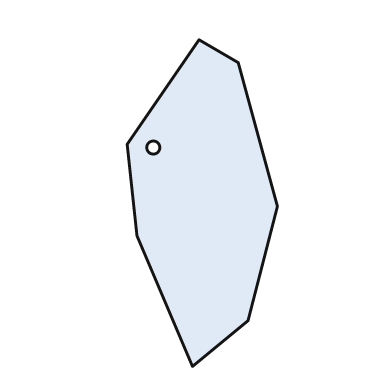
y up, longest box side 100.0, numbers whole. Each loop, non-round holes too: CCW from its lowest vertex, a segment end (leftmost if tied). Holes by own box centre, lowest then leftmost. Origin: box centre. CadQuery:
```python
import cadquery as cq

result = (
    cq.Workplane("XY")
    .moveTo(-3.0, -50.0)
    .lineTo(14.0, -36.0)
    .lineTo(23.0, -1.0)
    .lineTo(11.0, 43.0)
    .lineTo(-1.0, 50.0)
    .lineTo(-23.0, 18.0)
    .lineTo(-20.0, -10.0)
    .close()
    .moveTo(-15.0, 17.0)
    .circle(2.0)
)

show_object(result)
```